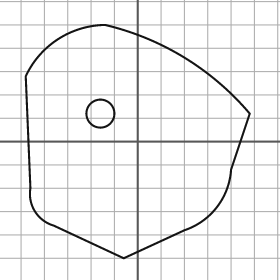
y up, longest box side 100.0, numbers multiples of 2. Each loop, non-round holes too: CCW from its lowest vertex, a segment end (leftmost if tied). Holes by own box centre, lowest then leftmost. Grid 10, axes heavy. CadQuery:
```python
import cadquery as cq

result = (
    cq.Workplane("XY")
    .moveTo(-6.0, -50.0)
    .lineTo(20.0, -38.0)
    .threePointArc((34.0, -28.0), (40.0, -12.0))
    .lineTo(48.0, 12.0)
    .threePointArc((20.0, 36.0), (-14.0, 50.0))
    .threePointArc((-34.0, 44.0), (-48.0, 28.0))
    .lineTo(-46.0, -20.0)
    .threePointArc((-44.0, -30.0), (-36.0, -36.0))
    .close()
    .moveTo(-16.0, 12.0)
    .circle(6.0)
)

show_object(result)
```